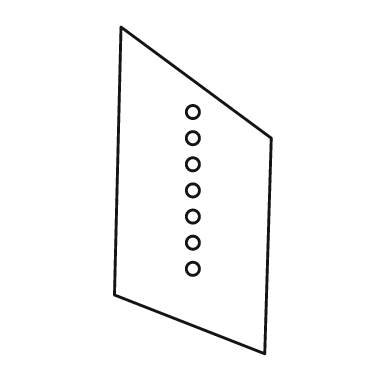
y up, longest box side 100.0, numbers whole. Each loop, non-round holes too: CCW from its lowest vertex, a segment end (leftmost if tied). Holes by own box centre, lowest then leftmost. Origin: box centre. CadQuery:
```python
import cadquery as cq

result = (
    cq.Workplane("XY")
    .moveTo(22.0, -50.0)
    .lineTo(24.0, 16.0)
    .lineTo(-22.0, 50.0)
    .lineTo(-24.0, -32.0)
    .close()
    .moveTo(0.0, -24.0)
    .circle(2.0)
    .moveTo(0.0, -16.0)
    .circle(2.0)
    .moveTo(0.0, -8.0)
    .circle(2.0)
    .moveTo(0.0, 0.0)
    .circle(2.0)
    .moveTo(0.0, 8.0)
    .circle(2.0)
    .moveTo(0.0, 16.0)
    .circle(2.0)
    .moveTo(0.0, 24.0)
    .circle(2.0)
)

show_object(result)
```